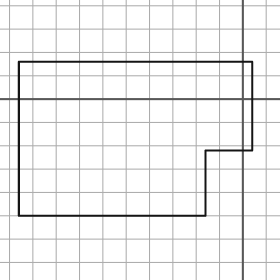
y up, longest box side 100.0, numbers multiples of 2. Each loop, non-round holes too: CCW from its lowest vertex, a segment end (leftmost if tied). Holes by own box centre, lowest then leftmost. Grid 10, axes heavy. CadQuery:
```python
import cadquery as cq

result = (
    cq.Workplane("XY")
    .moveTo(-96.0, -50.0)
    .lineTo(-16.0, -50.0)
    .lineTo(-16.0, -22.0)
    .lineTo(4.0, -22.0)
    .lineTo(4.0, 16.0)
    .lineTo(-96.0, 16.0)
    .close()
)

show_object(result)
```